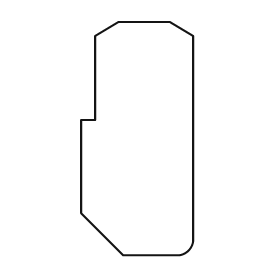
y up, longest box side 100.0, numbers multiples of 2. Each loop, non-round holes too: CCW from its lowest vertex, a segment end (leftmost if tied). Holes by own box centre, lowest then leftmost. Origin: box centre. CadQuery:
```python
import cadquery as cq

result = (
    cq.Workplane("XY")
    .moveTo(-6.0, -50.0)
    .lineTo(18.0, -50.0)
    .threePointArc((22.0, -48.0), (24.0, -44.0))
    .lineTo(24.0, 44.0)
    .lineTo(14.0, 50.0)
    .lineTo(-8.0, 50.0)
    .lineTo(-18.0, 44.0)
    .lineTo(-18.0, 8.0)
    .lineTo(-24.0, 8.0)
    .lineTo(-24.0, -32.0)
    .close()
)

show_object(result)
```